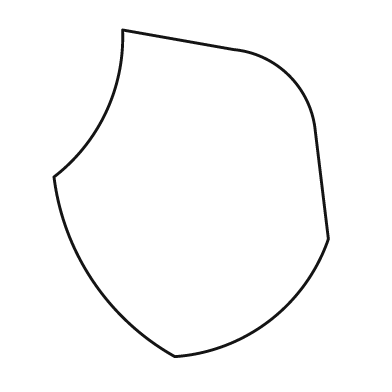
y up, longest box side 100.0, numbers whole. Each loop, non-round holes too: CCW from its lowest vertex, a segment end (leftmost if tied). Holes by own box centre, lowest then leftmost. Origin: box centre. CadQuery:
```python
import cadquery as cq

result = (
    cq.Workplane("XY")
    .moveTo(-5.0, -50.0)
    .threePointArc((24.0, -39.0), (42.0, -14.0))
    .lineTo(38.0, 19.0)
    .threePointArc((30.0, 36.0), (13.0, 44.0))
    .lineTo(-21.0, 50.0)
    .threePointArc((-26.0, 25.0), (-42.0, 5.0))
    .threePointArc((-30.0, -27.0), (-5.0, -50.0))
    .close()
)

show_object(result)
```